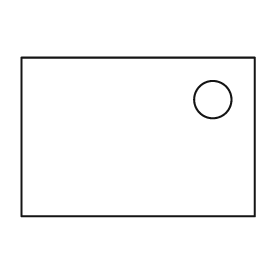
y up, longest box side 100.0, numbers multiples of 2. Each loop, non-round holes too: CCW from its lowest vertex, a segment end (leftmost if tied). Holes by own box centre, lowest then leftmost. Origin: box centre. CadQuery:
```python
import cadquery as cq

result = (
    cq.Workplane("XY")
    .moveTo(-50.0, -34.0)
    .lineTo(50.0, -34.0)
    .lineTo(50.0, 34.0)
    .lineTo(-50.0, 34.0)
    .close()
    .moveTo(32.0, 16.0)
    .circle(8.0)
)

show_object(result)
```